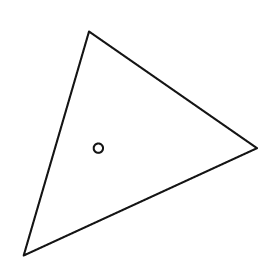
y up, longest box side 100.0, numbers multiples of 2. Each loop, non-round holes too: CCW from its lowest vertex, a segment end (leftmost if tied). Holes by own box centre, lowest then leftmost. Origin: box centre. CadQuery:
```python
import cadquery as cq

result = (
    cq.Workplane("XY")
    .moveTo(-50.0, -48.0)
    .lineTo(50.0, -2.0)
    .lineTo(-22.0, 48.0)
    .close()
    .moveTo(-18.0, -2.0)
    .circle(2.0)
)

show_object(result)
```